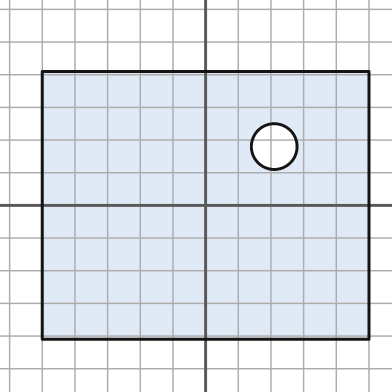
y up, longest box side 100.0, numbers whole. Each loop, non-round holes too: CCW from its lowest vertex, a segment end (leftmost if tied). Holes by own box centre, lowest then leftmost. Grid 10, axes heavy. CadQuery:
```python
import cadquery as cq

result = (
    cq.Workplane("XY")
    .moveTo(-50.0, -41.0)
    .lineTo(50.0, -41.0)
    .lineTo(50.0, 41.0)
    .lineTo(-50.0, 41.0)
    .close()
    .moveTo(21.0, 18.0)
    .circle(7.0)
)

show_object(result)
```